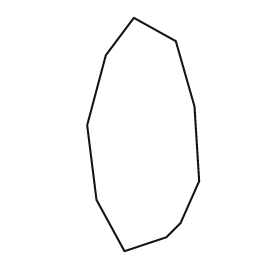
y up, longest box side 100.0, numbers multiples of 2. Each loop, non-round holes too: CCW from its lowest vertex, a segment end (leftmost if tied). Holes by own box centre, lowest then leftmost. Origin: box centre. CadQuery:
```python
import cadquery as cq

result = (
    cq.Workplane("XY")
    .moveTo(-8.0, -50.0)
    .lineTo(10.0, -44.0)
    .lineTo(16.0, -38.0)
    .lineTo(24.0, -20.0)
    .lineTo(22.0, 12.0)
    .lineTo(14.0, 40.0)
    .lineTo(-4.0, 50.0)
    .lineTo(-16.0, 34.0)
    .lineTo(-24.0, 4.0)
    .lineTo(-20.0, -28.0)
    .close()
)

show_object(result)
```